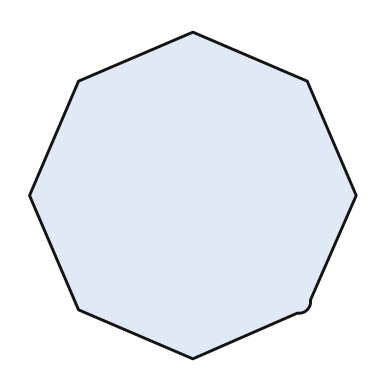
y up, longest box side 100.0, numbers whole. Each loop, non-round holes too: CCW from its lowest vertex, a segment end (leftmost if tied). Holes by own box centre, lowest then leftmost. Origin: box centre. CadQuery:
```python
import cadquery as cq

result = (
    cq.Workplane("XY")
    .moveTo(0.0, -50.0)
    .lineTo(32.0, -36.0)
    .threePointArc((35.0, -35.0), (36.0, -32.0))
    .lineTo(50.0, 0.0)
    .lineTo(35.0, 35.0)
    .lineTo(0.0, 50.0)
    .lineTo(-35.0, 35.0)
    .lineTo(-50.0, 0.0)
    .lineTo(-35.0, -35.0)
    .close()
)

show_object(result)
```